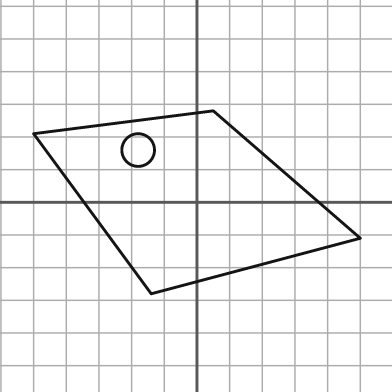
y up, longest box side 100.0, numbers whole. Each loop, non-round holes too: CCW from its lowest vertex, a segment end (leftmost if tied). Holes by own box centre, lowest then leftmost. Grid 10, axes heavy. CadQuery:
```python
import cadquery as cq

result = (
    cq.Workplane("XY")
    .moveTo(-14.0, -28.0)
    .lineTo(50.0, -11.0)
    .lineTo(5.0, 28.0)
    .lineTo(-50.0, 21.0)
    .close()
    .moveTo(-18.0, 16.0)
    .circle(5.0)
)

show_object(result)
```